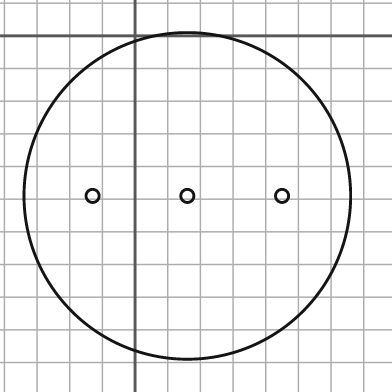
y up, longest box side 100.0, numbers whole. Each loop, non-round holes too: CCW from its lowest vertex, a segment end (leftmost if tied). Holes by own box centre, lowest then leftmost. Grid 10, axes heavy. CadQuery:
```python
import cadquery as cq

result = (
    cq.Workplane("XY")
    .moveTo(16.0, -49.0)
    .circle(50.0)
    .moveTo(-13.0, -49.0)
    .circle(2.0)
    .moveTo(16.0, -49.0)
    .circle(2.0)
    .moveTo(45.0, -49.0)
    .circle(2.0)
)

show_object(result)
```